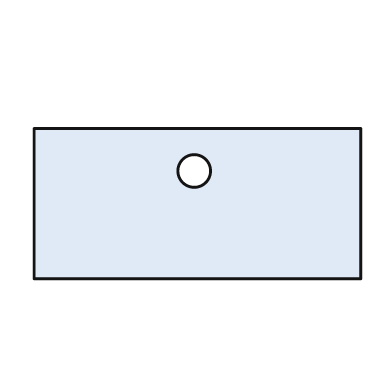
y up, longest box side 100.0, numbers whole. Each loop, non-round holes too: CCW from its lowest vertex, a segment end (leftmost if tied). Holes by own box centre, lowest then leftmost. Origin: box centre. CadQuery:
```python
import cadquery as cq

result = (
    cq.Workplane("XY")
    .moveTo(-50.0, -23.0)
    .lineTo(50.0, -23.0)
    .lineTo(50.0, 23.0)
    .lineTo(-50.0, 23.0)
    .close()
    .moveTo(-1.0, 10.0)
    .circle(5.0)
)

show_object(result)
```